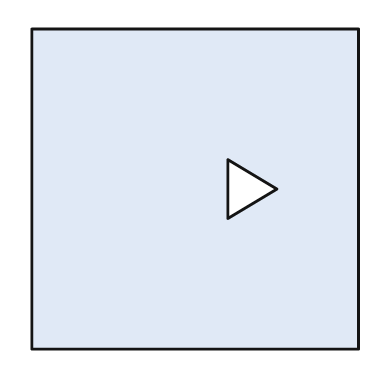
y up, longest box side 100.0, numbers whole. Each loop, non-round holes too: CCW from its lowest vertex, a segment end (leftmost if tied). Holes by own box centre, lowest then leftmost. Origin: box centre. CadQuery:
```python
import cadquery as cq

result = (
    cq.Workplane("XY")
    .moveTo(-50.0, -49.0)
    .lineTo(50.0, -49.0)
    .lineTo(50.0, 49.0)
    .lineTo(-50.0, 49.0)
    .close()
    .moveTo(10.0, -9.0)
    .lineTo(25.0, 0.0)
    .lineTo(10.0, 9.0)
    .close()
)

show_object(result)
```